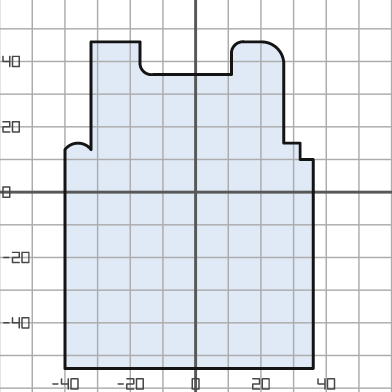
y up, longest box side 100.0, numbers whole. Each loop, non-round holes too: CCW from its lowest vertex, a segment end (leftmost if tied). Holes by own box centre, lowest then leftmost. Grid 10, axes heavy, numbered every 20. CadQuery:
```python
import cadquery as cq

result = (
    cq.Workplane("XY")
    .moveTo(-40.0, -54.0)
    .lineTo(36.0, -54.0)
    .lineTo(36.0, 10.0)
    .lineTo(32.0, 10.0)
    .lineTo(32.0, 15.0)
    .lineTo(27.0, 15.0)
    .lineTo(27.0, 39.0)
    .threePointArc((25.0, 44.0), (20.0, 46.0))
    .lineTo(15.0, 46.0)
    .threePointArc((12.0, 45.0), (11.0, 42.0))
    .lineTo(11.0, 36.0)
    .lineTo(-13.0, 36.0)
    .threePointArc((-16.0, 37.0), (-17.0, 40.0))
    .lineTo(-17.0, 46.0)
    .lineTo(-32.0, 46.0)
    .lineTo(-32.0, 13.0)
    .threePointArc((-36.0, 15.0), (-40.0, 13.0))
    .close()
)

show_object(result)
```